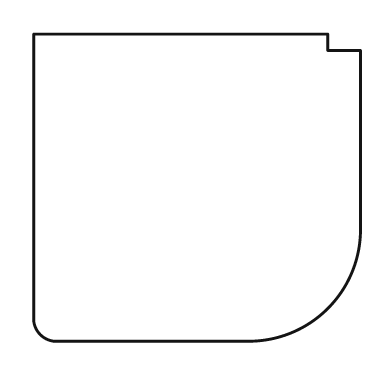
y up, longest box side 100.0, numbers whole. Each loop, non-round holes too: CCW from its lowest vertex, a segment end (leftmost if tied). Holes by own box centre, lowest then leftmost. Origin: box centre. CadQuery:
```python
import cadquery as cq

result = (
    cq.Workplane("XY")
    .moveTo(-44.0, -47.0)
    .lineTo(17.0, -47.0)
    .threePointArc((40.0, -37.0), (50.0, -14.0))
    .lineTo(50.0, 42.0)
    .lineTo(40.0, 42.0)
    .lineTo(40.0, 47.0)
    .lineTo(-50.0, 47.0)
    .lineTo(-50.0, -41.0)
    .threePointArc((-48.0, -45.0), (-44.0, -47.0))
    .close()
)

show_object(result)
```